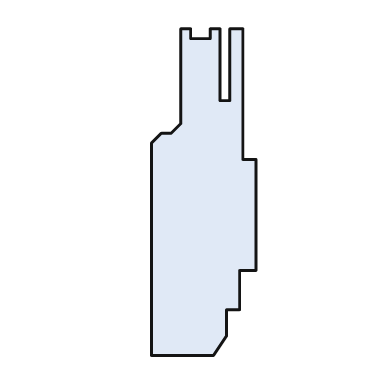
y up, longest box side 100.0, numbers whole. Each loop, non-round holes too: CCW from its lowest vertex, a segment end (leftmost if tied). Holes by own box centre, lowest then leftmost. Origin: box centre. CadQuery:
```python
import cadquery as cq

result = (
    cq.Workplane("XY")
    .moveTo(-16.0, -50.0)
    .lineTo(3.0, -50.0)
    .lineTo(7.0, -44.0)
    .lineTo(7.0, -36.0)
    .lineTo(11.0, -36.0)
    .lineTo(11.0, -24.0)
    .lineTo(16.0, -24.0)
    .lineTo(16.0, 10.0)
    .lineTo(12.0, 10.0)
    .lineTo(12.0, 50.0)
    .lineTo(8.0, 50.0)
    .lineTo(8.0, 28.0)
    .lineTo(5.0, 28.0)
    .lineTo(5.0, 50.0)
    .lineTo(2.0, 50.0)
    .lineTo(2.0, 47.0)
    .lineTo(-4.0, 47.0)
    .lineTo(-4.0, 50.0)
    .lineTo(-7.0, 50.0)
    .lineTo(-7.0, 21.0)
    .lineTo(-10.0, 18.0)
    .lineTo(-13.0, 18.0)
    .lineTo(-16.0, 15.0)
    .close()
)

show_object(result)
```